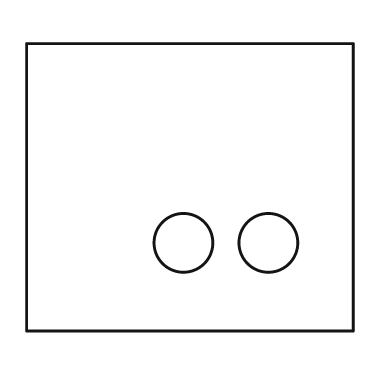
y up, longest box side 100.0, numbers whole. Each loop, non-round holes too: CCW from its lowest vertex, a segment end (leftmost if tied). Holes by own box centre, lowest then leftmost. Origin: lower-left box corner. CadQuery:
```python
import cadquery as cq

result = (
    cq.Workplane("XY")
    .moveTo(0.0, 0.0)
    .lineTo(100.0, 0.0)
    .lineTo(100.0, 88.0)
    .lineTo(0.0, 88.0)
    .close()
    .moveTo(48.0, 27.0)
    .circle(9.0)
    .moveTo(74.0, 27.0)
    .circle(9.0)
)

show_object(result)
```